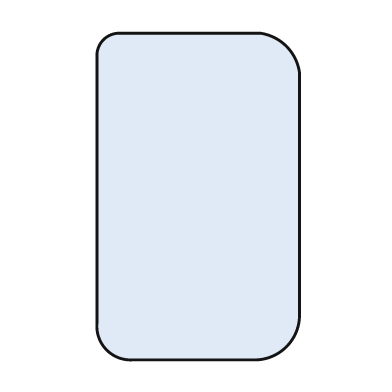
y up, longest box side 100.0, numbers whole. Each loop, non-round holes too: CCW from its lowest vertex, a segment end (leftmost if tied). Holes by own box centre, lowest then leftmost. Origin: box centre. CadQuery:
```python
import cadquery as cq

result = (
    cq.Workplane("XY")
    .moveTo(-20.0, -50.0)
    .lineTo(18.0, -50.0)
    .threePointArc((27.0, -46.0), (31.0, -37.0))
    .lineTo(31.0, 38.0)
    .threePointArc((27.0, 46.0), (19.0, 50.0))
    .lineTo(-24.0, 50.0)
    .threePointArc((-29.0, 48.0), (-31.0, 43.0))
    .lineTo(-31.0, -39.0)
    .threePointArc((-28.0, -47.0), (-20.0, -50.0))
    .close()
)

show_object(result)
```